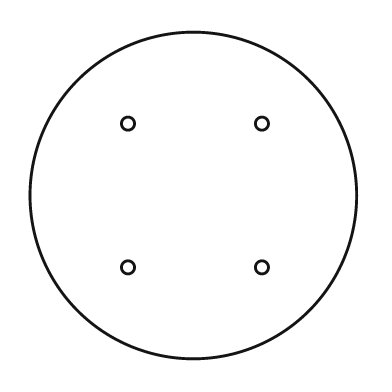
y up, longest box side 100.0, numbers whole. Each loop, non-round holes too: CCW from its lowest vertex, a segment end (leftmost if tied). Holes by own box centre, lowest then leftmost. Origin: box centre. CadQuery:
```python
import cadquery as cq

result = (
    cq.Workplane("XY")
    .moveTo(0.0, 0.0)
    .circle(50.0)
    .moveTo(-20.0, -22.0)
    .circle(2.0)
    .moveTo(21.0, -22.0)
    .circle(2.0)
    .moveTo(-20.0, 22.0)
    .circle(2.0)
    .moveTo(21.0, 22.0)
    .circle(2.0)
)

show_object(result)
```